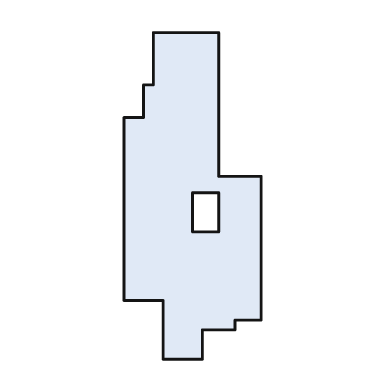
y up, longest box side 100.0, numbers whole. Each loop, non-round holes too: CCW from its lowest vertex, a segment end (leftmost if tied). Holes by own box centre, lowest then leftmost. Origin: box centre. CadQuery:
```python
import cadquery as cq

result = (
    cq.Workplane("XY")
    .moveTo(-9.0, -50.0)
    .lineTo(3.0, -50.0)
    .lineTo(3.0, -41.0)
    .lineTo(13.0, -41.0)
    .lineTo(13.0, -38.0)
    .lineTo(21.0, -38.0)
    .lineTo(21.0, 6.0)
    .lineTo(8.0, 6.0)
    .lineTo(8.0, 50.0)
    .lineTo(-12.0, 50.0)
    .lineTo(-12.0, 34.0)
    .lineTo(-15.0, 34.0)
    .lineTo(-15.0, 24.0)
    .lineTo(-21.0, 24.0)
    .lineTo(-21.0, -32.0)
    .lineTo(-9.0, -32.0)
    .close()
    .moveTo(0.0, -11.0)
    .lineTo(8.0, -11.0)
    .lineTo(8.0, 1.0)
    .lineTo(0.0, 1.0)
    .close()
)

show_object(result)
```